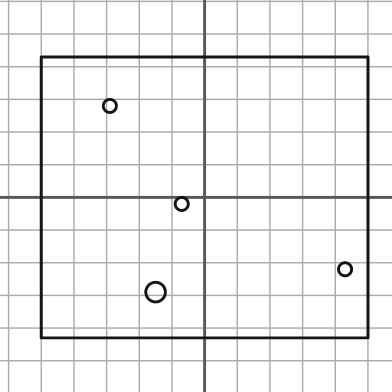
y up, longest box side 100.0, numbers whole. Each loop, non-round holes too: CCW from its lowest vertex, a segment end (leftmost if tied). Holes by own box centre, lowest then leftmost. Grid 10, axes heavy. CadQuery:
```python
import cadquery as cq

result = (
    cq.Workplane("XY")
    .moveTo(-50.0, -43.0)
    .lineTo(50.0, -43.0)
    .lineTo(50.0, 43.0)
    .lineTo(-50.0, 43.0)
    .close()
    .moveTo(-15.0, -29.0)
    .circle(3.0)
    .moveTo(43.0, -22.0)
    .circle(2.0)
    .moveTo(-7.0, -2.0)
    .circle(2.0)
    .moveTo(-29.0, 28.0)
    .circle(2.0)
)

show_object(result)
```